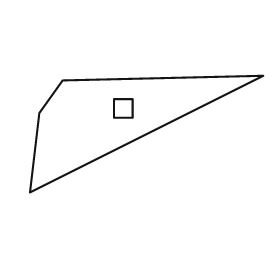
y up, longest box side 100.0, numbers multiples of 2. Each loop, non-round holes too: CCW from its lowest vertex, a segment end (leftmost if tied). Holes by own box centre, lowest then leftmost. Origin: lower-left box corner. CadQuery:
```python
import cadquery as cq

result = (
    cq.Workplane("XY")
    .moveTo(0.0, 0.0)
    .lineTo(100.0, 50.0)
    .lineTo(14.0, 48.0)
    .lineTo(4.0, 34.0)
    .close()
    .moveTo(36.0, 32.0)
    .lineTo(44.0, 32.0)
    .lineTo(44.0, 40.0)
    .lineTo(36.0, 40.0)
    .close()
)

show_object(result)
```